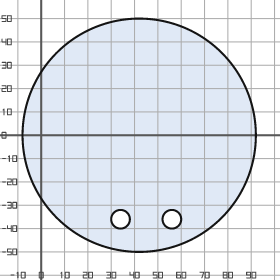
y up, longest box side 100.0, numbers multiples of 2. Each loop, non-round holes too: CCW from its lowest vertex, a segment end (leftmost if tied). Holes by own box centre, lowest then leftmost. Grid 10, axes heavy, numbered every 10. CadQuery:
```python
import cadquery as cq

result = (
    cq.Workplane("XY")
    .moveTo(42.0, 0.0)
    .circle(50.0)
    .moveTo(34.0, -36.0)
    .circle(4.0)
    .moveTo(56.0, -36.0)
    .circle(4.0)
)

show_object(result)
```